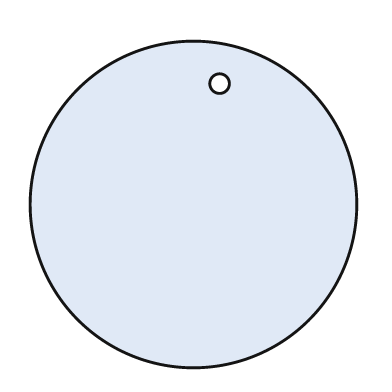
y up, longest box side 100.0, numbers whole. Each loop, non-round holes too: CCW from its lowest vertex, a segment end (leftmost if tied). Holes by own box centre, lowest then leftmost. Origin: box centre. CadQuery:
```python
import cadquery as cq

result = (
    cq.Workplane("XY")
    .moveTo(0.0, 0.0)
    .circle(50.0)
    .moveTo(8.0, 37.0)
    .circle(3.0)
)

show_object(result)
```